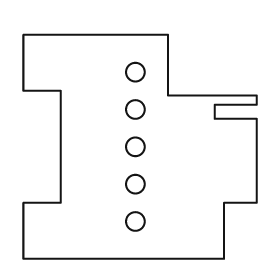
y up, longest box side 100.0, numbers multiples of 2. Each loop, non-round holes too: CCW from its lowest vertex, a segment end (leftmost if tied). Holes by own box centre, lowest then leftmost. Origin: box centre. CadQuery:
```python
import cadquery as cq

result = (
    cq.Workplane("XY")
    .moveTo(-50.0, -48.0)
    .lineTo(36.0, -48.0)
    .lineTo(36.0, -24.0)
    .lineTo(50.0, -24.0)
    .lineTo(50.0, 12.0)
    .lineTo(32.0, 12.0)
    .lineTo(32.0, 18.0)
    .lineTo(50.0, 18.0)
    .lineTo(50.0, 22.0)
    .lineTo(12.0, 22.0)
    .lineTo(12.0, 48.0)
    .lineTo(-50.0, 48.0)
    .lineTo(-50.0, 24.0)
    .lineTo(-34.0, 24.0)
    .lineTo(-34.0, -24.0)
    .lineTo(-50.0, -24.0)
    .close()
    .moveTo(-2.0, -32.0)
    .circle(4.0)
    .moveTo(-2.0, -16.0)
    .circle(4.0)
    .moveTo(-2.0, 0.0)
    .circle(4.0)
    .moveTo(-2.0, 16.0)
    .circle(4.0)
    .moveTo(-2.0, 32.0)
    .circle(4.0)
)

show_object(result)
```